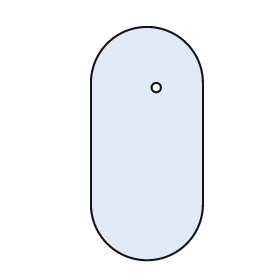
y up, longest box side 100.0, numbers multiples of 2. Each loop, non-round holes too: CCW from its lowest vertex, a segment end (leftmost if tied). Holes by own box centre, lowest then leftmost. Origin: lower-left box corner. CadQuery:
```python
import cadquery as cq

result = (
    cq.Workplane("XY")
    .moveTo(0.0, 24.0)
    .threePointArc((24.0, 0.0), (48.0, 24.0))
    .lineTo(48.0, 76.0)
    .threePointArc((24.0, 100.0), (0.0, 76.0))
    .close()
    .moveTo(28.0, 74.0)
    .circle(2.0)
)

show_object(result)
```